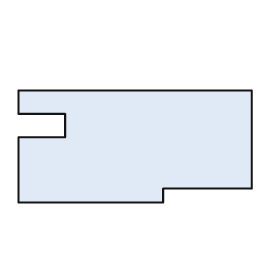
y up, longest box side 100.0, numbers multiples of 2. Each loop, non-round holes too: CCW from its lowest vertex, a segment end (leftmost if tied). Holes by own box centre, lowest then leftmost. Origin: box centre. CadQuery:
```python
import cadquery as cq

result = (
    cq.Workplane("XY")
    .moveTo(-50.0, -24.0)
    .lineTo(12.0, -24.0)
    .lineTo(12.0, -18.0)
    .lineTo(50.0, -18.0)
    .lineTo(50.0, 24.0)
    .lineTo(-50.0, 24.0)
    .lineTo(-50.0, 14.0)
    .lineTo(-30.0, 14.0)
    .lineTo(-30.0, 4.0)
    .lineTo(-50.0, 4.0)
    .close()
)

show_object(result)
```